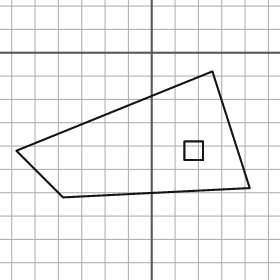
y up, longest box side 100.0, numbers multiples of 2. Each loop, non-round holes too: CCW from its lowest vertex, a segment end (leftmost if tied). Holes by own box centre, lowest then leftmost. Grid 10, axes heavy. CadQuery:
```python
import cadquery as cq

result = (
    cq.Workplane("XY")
    .moveTo(-38.0, -62.0)
    .lineTo(42.0, -58.0)
    .lineTo(26.0, -8.0)
    .lineTo(-58.0, -42.0)
    .close()
    .moveTo(14.0, -46.0)
    .lineTo(22.0, -46.0)
    .lineTo(22.0, -38.0)
    .lineTo(14.0, -38.0)
    .close()
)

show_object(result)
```